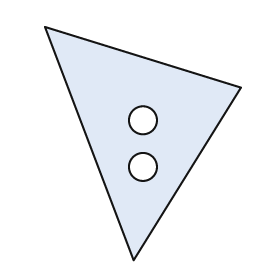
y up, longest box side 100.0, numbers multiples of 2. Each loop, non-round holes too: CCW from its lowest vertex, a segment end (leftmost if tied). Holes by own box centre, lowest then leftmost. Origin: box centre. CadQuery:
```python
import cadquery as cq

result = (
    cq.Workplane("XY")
    .moveTo(-4.0, -50.0)
    .lineTo(42.0, 24.0)
    .lineTo(-42.0, 50.0)
    .close()
    .moveTo(0.0, -10.0)
    .circle(6.0)
    .moveTo(0.0, 10.0)
    .circle(6.0)
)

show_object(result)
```